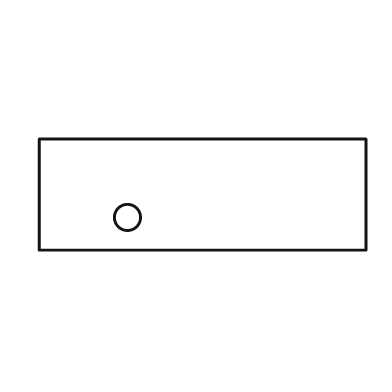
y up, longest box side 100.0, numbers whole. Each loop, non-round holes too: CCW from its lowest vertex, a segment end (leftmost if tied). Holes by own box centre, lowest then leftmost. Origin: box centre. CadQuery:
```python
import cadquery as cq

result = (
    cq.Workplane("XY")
    .moveTo(-50.0, -17.0)
    .lineTo(50.0, -17.0)
    .lineTo(50.0, 17.0)
    .lineTo(-50.0, 17.0)
    .close()
    .moveTo(-23.0, -7.0)
    .circle(4.0)
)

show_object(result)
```